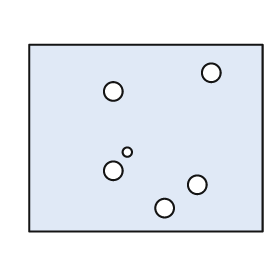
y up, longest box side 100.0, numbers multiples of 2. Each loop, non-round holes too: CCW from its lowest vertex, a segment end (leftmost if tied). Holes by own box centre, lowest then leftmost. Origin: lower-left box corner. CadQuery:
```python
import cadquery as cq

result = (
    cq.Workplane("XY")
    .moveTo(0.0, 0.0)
    .lineTo(100.0, 0.0)
    .lineTo(100.0, 80.0)
    .lineTo(0.0, 80.0)
    .close()
    .moveTo(58.0, 10.0)
    .circle(4.0)
    .moveTo(72.0, 20.0)
    .circle(4.0)
    .moveTo(36.0, 26.0)
    .circle(4.0)
    .moveTo(42.0, 34.0)
    .circle(2.0)
    .moveTo(36.0, 60.0)
    .circle(4.0)
    .moveTo(78.0, 68.0)
    .circle(4.0)
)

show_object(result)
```